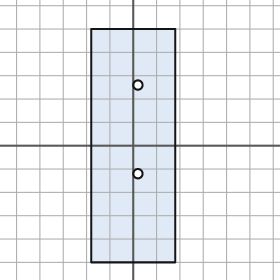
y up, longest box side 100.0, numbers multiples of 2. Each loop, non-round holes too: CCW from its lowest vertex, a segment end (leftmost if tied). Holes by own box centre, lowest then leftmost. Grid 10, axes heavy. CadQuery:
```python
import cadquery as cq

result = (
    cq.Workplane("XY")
    .moveTo(-18.0, -50.0)
    .lineTo(18.0, -50.0)
    .lineTo(18.0, 50.0)
    .lineTo(-18.0, 50.0)
    .close()
    .moveTo(2.0, -12.0)
    .circle(2.0)
    .moveTo(2.0, 26.0)
    .circle(2.0)
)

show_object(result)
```